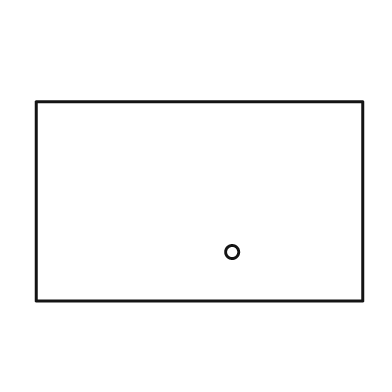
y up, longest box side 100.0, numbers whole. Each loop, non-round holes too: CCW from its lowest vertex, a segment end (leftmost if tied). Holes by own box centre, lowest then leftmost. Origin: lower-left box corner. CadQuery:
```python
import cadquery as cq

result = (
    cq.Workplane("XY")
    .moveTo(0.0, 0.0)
    .lineTo(100.0, 0.0)
    .lineTo(100.0, 61.0)
    .lineTo(0.0, 61.0)
    .close()
    .moveTo(60.0, 15.0)
    .circle(2.0)
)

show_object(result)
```